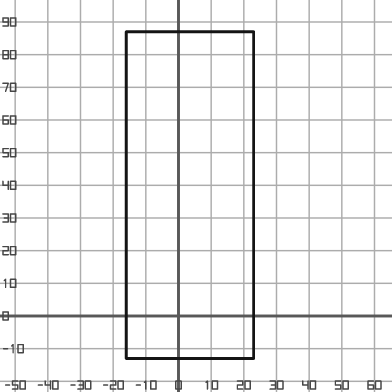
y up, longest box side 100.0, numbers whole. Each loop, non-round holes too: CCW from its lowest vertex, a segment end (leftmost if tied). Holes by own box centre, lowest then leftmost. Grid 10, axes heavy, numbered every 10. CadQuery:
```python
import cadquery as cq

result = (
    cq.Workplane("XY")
    .moveTo(-16.0, -13.0)
    .lineTo(23.0, -13.0)
    .lineTo(23.0, 87.0)
    .lineTo(-16.0, 87.0)
    .close()
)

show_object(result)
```